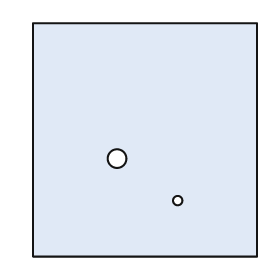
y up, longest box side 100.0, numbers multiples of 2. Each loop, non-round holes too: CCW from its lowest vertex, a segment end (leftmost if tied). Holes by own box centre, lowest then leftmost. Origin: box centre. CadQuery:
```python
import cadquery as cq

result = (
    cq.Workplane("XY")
    .moveTo(-48.0, -50.0)
    .lineTo(48.0, -50.0)
    .lineTo(48.0, 50.0)
    .lineTo(-48.0, 50.0)
    .close()
    .moveTo(14.0, -26.0)
    .circle(2.0)
    .moveTo(-12.0, -8.0)
    .circle(4.0)
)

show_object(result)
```